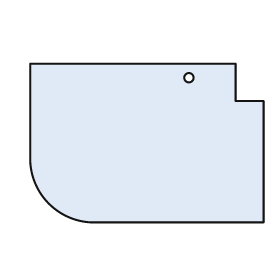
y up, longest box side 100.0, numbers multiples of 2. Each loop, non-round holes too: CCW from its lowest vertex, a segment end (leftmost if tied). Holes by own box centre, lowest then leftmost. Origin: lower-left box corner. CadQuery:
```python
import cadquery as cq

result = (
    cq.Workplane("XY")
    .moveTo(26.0, 0.0)
    .lineTo(100.0, 0.0)
    .lineTo(100.0, 52.0)
    .lineTo(88.0, 52.0)
    .lineTo(88.0, 68.0)
    .lineTo(0.0, 68.0)
    .lineTo(0.0, 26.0)
    .threePointArc((8.0, 8.0), (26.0, 0.0))
    .close()
    .moveTo(68.0, 62.0)
    .circle(2.0)
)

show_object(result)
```